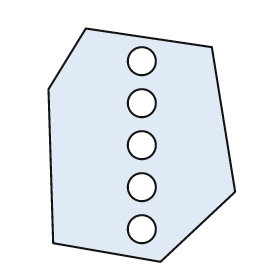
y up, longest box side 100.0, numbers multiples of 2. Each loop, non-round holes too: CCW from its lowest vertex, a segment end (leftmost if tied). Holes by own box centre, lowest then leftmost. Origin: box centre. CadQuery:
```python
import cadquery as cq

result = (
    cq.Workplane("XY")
    .moveTo(8.0, -50.0)
    .lineTo(40.0, -20.0)
    .lineTo(30.0, 42.0)
    .lineTo(-24.0, 50.0)
    .lineTo(-40.0, 24.0)
    .lineTo(-38.0, -42.0)
    .close()
    .moveTo(0.0, -36.0)
    .circle(6.0)
    .moveTo(0.0, -18.0)
    .circle(6.0)
    .moveTo(0.0, 0.0)
    .circle(6.0)
    .moveTo(0.0, 18.0)
    .circle(6.0)
    .moveTo(0.0, 36.0)
    .circle(6.0)
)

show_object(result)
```